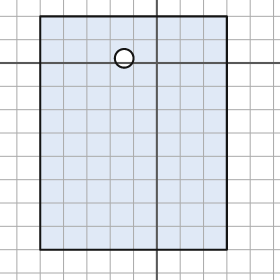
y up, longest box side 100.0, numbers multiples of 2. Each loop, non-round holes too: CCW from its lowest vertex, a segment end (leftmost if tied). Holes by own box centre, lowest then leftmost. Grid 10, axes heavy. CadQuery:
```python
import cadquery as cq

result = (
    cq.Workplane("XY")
    .moveTo(-50.0, -80.0)
    .lineTo(30.0, -80.0)
    .lineTo(30.0, 20.0)
    .lineTo(-50.0, 20.0)
    .close()
    .moveTo(-14.0, 2.0)
    .circle(4.0)
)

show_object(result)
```